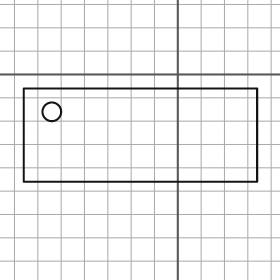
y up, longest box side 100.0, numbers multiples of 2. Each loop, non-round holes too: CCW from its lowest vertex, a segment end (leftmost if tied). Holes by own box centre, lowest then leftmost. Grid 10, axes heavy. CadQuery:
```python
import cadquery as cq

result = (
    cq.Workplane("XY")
    .moveTo(-66.0, -46.0)
    .lineTo(34.0, -46.0)
    .lineTo(34.0, -6.0)
    .lineTo(-66.0, -6.0)
    .close()
    .moveTo(-54.0, -16.0)
    .circle(4.0)
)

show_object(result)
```